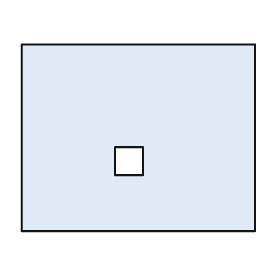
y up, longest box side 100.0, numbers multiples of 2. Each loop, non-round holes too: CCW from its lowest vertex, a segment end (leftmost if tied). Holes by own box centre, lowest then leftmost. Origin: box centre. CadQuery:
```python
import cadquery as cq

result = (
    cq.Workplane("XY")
    .moveTo(-50.0, -40.0)
    .lineTo(50.0, -40.0)
    .lineTo(50.0, 40.0)
    .lineTo(-50.0, 40.0)
    .close()
    .moveTo(-10.0, -16.0)
    .lineTo(2.0, -16.0)
    .lineTo(2.0, -4.0)
    .lineTo(-10.0, -4.0)
    .close()
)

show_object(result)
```